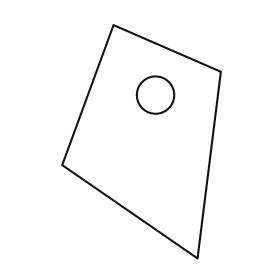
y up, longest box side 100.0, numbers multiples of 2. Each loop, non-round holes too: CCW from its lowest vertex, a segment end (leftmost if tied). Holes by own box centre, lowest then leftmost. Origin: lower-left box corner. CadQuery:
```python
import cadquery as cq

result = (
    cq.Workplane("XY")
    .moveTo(58.0, 0.0)
    .lineTo(68.0, 80.0)
    .lineTo(22.0, 100.0)
    .lineTo(0.0, 40.0)
    .close()
    .moveTo(40.0, 70.0)
    .circle(8.0)
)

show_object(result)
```